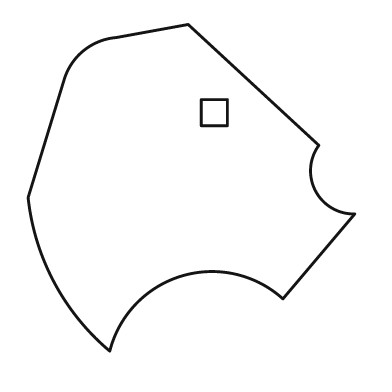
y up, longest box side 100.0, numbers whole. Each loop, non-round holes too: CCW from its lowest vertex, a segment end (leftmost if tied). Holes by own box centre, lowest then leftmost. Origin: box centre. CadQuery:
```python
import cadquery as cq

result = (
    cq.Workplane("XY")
    .moveTo(-25.0, -50.0)
    .threePointArc((-3.0, -27.0), (28.0, -34.0))
    .lineTo(50.0, -8.0)
    .threePointArc((38.0, -1.0), (39.0, 13.0))
    .lineTo(-1.0, 50.0)
    .lineTo(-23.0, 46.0)
    .threePointArc((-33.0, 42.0), (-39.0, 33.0))
    .lineTo(-50.0, -3.0)
    .threePointArc((-42.0, -29.0), (-25.0, -50.0))
    .close()
    .moveTo(3.0, 19.0)
    .lineTo(11.0, 19.0)
    .lineTo(11.0, 27.0)
    .lineTo(3.0, 27.0)
    .close()
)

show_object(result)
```